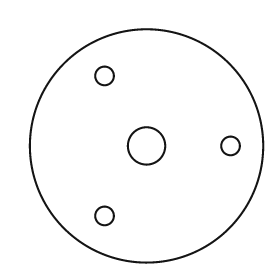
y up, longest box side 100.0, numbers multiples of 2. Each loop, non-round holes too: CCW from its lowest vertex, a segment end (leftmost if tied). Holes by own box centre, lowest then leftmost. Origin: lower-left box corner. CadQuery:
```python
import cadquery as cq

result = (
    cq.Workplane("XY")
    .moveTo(50.0, 50.0)
    .circle(50.0)
    .moveTo(32.0, 20.0)
    .circle(4.0)
    .moveTo(50.0, 50.0)
    .circle(8.0)
    .moveTo(86.0, 50.0)
    .circle(4.0)
    .moveTo(32.0, 80.0)
    .circle(4.0)
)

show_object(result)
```